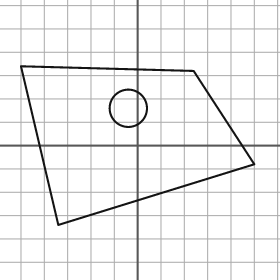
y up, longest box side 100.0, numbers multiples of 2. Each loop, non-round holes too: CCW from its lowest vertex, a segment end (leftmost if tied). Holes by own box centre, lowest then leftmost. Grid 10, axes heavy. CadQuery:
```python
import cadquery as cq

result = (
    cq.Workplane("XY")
    .moveTo(-34.0, -34.0)
    .lineTo(50.0, -8.0)
    .lineTo(24.0, 32.0)
    .lineTo(-50.0, 34.0)
    .close()
    .moveTo(-4.0, 16.0)
    .circle(8.0)
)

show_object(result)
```